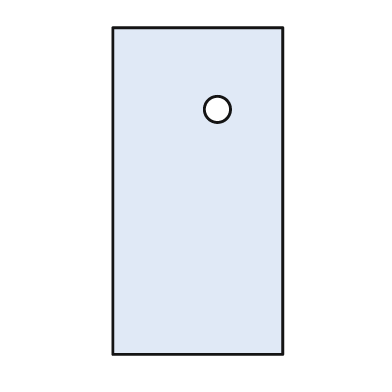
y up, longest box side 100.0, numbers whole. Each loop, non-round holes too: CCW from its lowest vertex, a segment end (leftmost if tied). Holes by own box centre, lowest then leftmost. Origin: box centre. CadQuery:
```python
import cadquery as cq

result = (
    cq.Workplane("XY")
    .moveTo(-26.0, -50.0)
    .lineTo(26.0, -50.0)
    .lineTo(26.0, 50.0)
    .lineTo(-26.0, 50.0)
    .close()
    .moveTo(6.0, 25.0)
    .circle(4.0)
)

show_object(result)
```